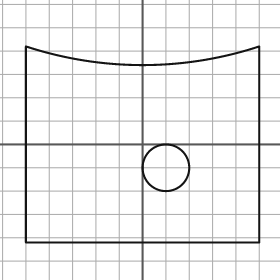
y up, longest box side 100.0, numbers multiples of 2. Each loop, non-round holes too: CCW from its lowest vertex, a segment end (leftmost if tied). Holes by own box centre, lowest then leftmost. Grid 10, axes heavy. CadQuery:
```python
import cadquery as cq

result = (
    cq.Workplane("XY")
    .moveTo(-50.0, -42.0)
    .lineTo(50.0, -42.0)
    .lineTo(50.0, 42.0)
    .threePointArc((0.0, 34.0), (-50.0, 42.0))
    .close()
    .moveTo(10.0, -10.0)
    .circle(10.0)
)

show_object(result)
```